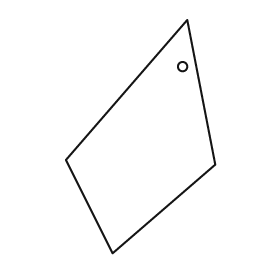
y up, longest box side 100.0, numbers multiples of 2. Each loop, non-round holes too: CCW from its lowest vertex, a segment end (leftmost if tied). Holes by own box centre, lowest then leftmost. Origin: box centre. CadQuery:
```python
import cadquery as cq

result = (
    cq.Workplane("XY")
    .moveTo(-12.0, -50.0)
    .lineTo(32.0, -12.0)
    .lineTo(20.0, 50.0)
    .lineTo(-32.0, -10.0)
    .close()
    .moveTo(18.0, 30.0)
    .circle(2.0)
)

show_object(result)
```